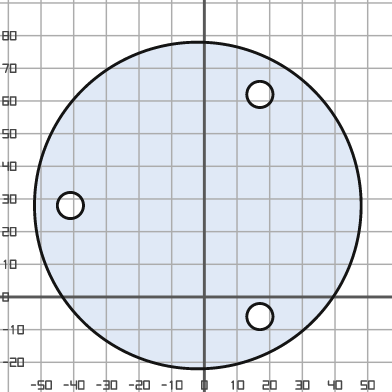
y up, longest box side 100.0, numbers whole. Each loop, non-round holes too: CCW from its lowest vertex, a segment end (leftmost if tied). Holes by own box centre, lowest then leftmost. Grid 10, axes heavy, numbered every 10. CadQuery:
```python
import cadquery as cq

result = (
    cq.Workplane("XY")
    .moveTo(-2.0, 28.0)
    .circle(50.0)
    .moveTo(17.0, -6.0)
    .circle(4.0)
    .moveTo(-41.0, 28.0)
    .circle(4.0)
    .moveTo(17.0, 62.0)
    .circle(4.0)
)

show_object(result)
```